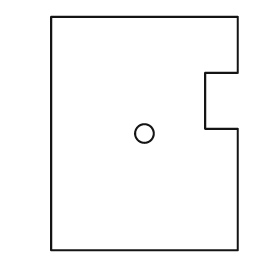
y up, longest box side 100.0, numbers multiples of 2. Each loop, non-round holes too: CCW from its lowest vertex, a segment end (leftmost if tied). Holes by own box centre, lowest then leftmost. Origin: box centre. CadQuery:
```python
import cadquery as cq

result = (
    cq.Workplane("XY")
    .moveTo(-40.0, -50.0)
    .lineTo(40.0, -50.0)
    .lineTo(40.0, 2.0)
    .lineTo(26.0, 2.0)
    .lineTo(26.0, 26.0)
    .lineTo(40.0, 26.0)
    .lineTo(40.0, 50.0)
    .lineTo(-40.0, 50.0)
    .close()
    .moveTo(0.0, 0.0)
    .circle(4.0)
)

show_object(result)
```